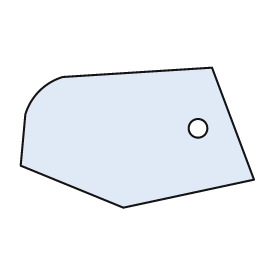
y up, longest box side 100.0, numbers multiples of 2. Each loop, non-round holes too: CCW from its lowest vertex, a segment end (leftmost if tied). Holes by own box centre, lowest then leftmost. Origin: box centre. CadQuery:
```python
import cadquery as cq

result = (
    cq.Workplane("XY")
    .moveTo(-6.0, -30.0)
    .lineTo(50.0, -18.0)
    .lineTo(32.0, 30.0)
    .lineTo(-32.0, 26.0)
    .threePointArc((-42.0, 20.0), (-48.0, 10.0))
    .lineTo(-50.0, -12.0)
    .close()
    .moveTo(26.0, 4.0)
    .circle(4.0)
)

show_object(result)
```